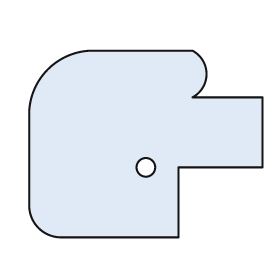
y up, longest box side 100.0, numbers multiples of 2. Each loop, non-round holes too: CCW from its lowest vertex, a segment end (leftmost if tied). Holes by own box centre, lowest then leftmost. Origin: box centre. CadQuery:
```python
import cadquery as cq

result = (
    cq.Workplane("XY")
    .moveTo(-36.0, -40.0)
    .lineTo(14.0, -40.0)
    .lineTo(14.0, -10.0)
    .lineTo(50.0, -10.0)
    .lineTo(50.0, 20.0)
    .lineTo(20.0, 20.0)
    .threePointArc((26.0, 30.0), (20.0, 40.0))
    .lineTo(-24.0, 40.0)
    .threePointArc((-42.0, 32.0), (-50.0, 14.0))
    .lineTo(-50.0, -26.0)
    .threePointArc((-46.0, -36.0), (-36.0, -40.0))
    .close()
    .moveTo(0.0, -10.0)
    .circle(4.0)
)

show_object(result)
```